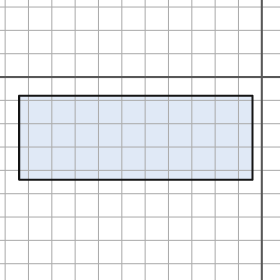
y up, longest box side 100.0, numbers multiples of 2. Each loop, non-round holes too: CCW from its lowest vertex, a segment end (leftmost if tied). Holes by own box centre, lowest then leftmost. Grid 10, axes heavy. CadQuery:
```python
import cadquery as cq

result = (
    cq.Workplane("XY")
    .moveTo(-104.0, -44.0)
    .lineTo(-4.0, -44.0)
    .lineTo(-4.0, -8.0)
    .lineTo(-104.0, -8.0)
    .close()
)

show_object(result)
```